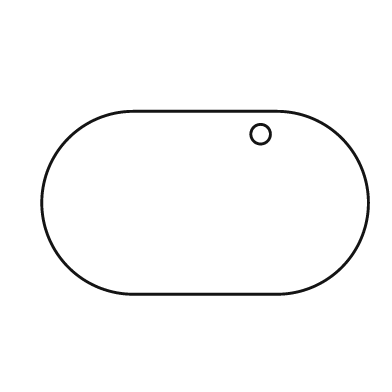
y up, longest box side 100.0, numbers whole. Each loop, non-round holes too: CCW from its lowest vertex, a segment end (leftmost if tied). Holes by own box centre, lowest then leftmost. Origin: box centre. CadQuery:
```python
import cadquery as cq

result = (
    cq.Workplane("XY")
    .moveTo(-22.0, -28.0)
    .lineTo(22.0, -28.0)
    .threePointArc((50.0, 0.0), (22.0, 28.0))
    .lineTo(-22.0, 28.0)
    .threePointArc((-50.0, 0.0), (-22.0, -28.0))
    .close()
    .moveTo(17.0, 21.0)
    .circle(3.0)
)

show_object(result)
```